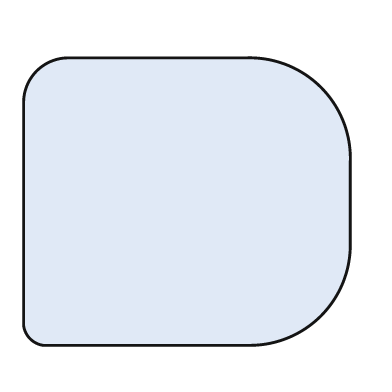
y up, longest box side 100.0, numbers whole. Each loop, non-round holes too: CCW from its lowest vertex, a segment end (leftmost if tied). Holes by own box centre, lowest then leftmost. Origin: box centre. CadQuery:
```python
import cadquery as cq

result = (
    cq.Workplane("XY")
    .moveTo(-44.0, -44.0)
    .lineTo(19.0, -44.0)
    .threePointArc((41.0, -35.0), (50.0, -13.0))
    .lineTo(50.0, 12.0)
    .threePointArc((41.0, 35.0), (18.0, 44.0))
    .lineTo(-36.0, 44.0)
    .threePointArc((-46.0, 40.0), (-50.0, 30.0))
    .lineTo(-50.0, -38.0)
    .threePointArc((-48.0, -42.0), (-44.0, -44.0))
    .close()
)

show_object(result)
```